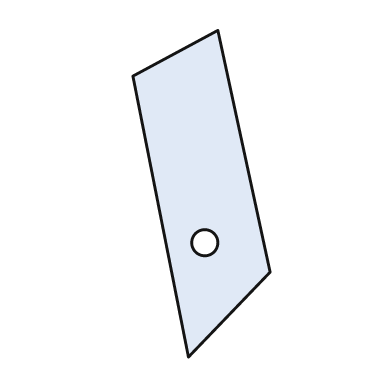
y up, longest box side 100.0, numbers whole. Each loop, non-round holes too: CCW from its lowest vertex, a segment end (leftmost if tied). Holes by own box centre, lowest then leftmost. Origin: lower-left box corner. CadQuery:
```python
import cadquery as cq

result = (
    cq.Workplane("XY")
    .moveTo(17.0, 0.0)
    .lineTo(42.0, 26.0)
    .lineTo(26.0, 100.0)
    .lineTo(0.0, 86.0)
    .close()
    .moveTo(22.0, 35.0)
    .circle(4.0)
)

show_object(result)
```